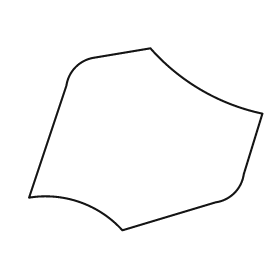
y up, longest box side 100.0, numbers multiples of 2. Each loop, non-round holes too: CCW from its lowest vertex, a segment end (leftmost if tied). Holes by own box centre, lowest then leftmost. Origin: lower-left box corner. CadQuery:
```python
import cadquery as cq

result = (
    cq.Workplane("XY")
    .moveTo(40.0, 0.0)
    .lineTo(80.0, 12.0)
    .threePointArc((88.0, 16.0), (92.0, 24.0))
    .lineTo(100.0, 50.0)
    .threePointArc((74.0, 60.0), (52.0, 78.0))
    .lineTo(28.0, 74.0)
    .threePointArc((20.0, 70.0), (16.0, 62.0))
    .lineTo(0.0, 14.0)
    .threePointArc((22.0, 12.0), (40.0, 0.0))
    .close()
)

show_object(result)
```